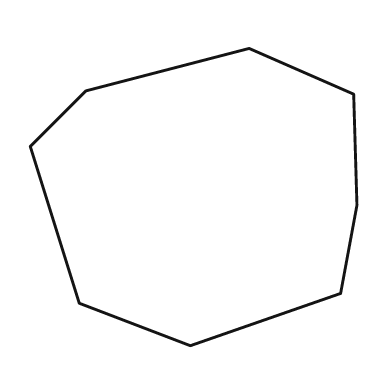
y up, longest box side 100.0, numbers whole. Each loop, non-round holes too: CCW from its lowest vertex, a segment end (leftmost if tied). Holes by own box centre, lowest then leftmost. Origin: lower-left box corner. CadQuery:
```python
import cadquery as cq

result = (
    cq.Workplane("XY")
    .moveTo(49.0, 0.0)
    .lineTo(95.0, 16.0)
    .lineTo(100.0, 43.0)
    .lineTo(99.0, 77.0)
    .lineTo(67.0, 91.0)
    .lineTo(17.0, 78.0)
    .lineTo(0.0, 61.0)
    .lineTo(15.0, 13.0)
    .close()
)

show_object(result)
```